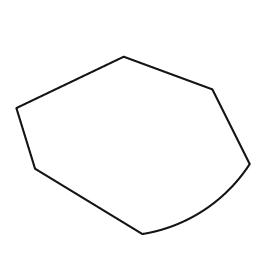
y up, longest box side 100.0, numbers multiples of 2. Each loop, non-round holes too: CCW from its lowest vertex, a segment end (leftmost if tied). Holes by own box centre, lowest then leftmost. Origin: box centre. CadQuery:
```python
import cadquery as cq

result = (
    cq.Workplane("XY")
    .moveTo(4.0, -38.0)
    .threePointArc((30.0, -28.0), (50.0, -8.0))
    .lineTo(34.0, 24.0)
    .lineTo(-4.0, 38.0)
    .lineTo(-50.0, 16.0)
    .lineTo(-42.0, -10.0)
    .close()
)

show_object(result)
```